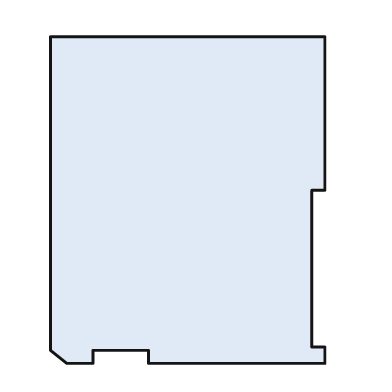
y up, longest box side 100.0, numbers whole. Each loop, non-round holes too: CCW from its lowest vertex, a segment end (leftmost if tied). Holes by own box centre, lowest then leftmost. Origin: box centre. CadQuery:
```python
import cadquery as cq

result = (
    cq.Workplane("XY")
    .moveTo(-37.0, -50.0)
    .lineTo(-29.0, -50.0)
    .lineTo(-29.0, -46.0)
    .lineTo(-12.0, -46.0)
    .lineTo(-12.0, -50.0)
    .lineTo(42.0, -50.0)
    .lineTo(42.0, -45.0)
    .lineTo(38.0, -45.0)
    .lineTo(38.0, 3.0)
    .lineTo(42.0, 3.0)
    .lineTo(42.0, 50.0)
    .lineTo(-42.0, 50.0)
    .lineTo(-42.0, -46.0)
    .close()
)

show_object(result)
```